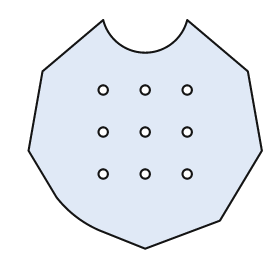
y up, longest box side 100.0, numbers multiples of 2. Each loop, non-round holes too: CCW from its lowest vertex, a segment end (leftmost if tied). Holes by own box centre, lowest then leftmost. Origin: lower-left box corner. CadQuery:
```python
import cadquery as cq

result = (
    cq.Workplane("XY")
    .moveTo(50.0, 0.0)
    .lineTo(82.0, 12.0)
    .lineTo(100.0, 42.0)
    .lineTo(94.0, 76.0)
    .lineTo(68.0, 98.0)
    .threePointArc((50.0, 84.0), (32.0, 98.0))
    .lineTo(6.0, 76.0)
    .lineTo(0.0, 42.0)
    .lineTo(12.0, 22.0)
    .threePointArc((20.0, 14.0), (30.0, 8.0))
    .close()
    .moveTo(32.0, 32.0)
    .circle(2.0)
    .moveTo(50.0, 32.0)
    .circle(2.0)
    .moveTo(68.0, 32.0)
    .circle(2.0)
    .moveTo(32.0, 50.0)
    .circle(2.0)
    .moveTo(50.0, 50.0)
    .circle(2.0)
    .moveTo(68.0, 50.0)
    .circle(2.0)
    .moveTo(32.0, 68.0)
    .circle(2.0)
    .moveTo(50.0, 68.0)
    .circle(2.0)
    .moveTo(68.0, 68.0)
    .circle(2.0)
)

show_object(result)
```